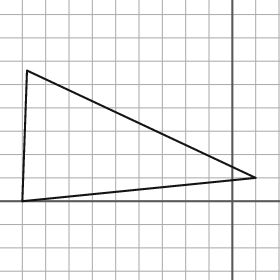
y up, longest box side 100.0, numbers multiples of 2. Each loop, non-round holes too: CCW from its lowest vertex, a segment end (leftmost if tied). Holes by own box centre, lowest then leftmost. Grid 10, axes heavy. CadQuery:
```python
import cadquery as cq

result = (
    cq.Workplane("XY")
    .moveTo(-90.0, 0.0)
    .lineTo(10.0, 10.0)
    .lineTo(-88.0, 56.0)
    .close()
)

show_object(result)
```